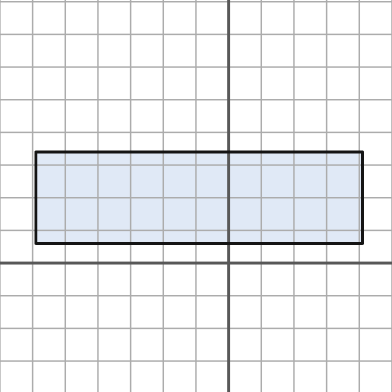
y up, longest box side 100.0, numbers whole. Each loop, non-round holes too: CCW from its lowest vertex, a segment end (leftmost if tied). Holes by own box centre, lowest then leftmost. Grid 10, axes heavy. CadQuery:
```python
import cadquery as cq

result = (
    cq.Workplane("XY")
    .moveTo(-59.0, 6.0)
    .lineTo(41.0, 6.0)
    .lineTo(41.0, 34.0)
    .lineTo(-59.0, 34.0)
    .close()
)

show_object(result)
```